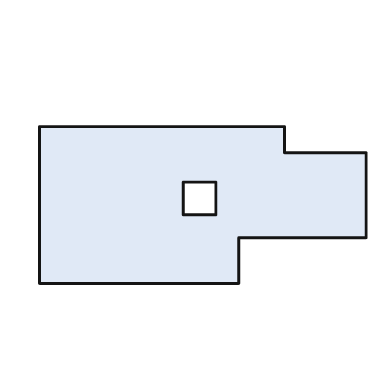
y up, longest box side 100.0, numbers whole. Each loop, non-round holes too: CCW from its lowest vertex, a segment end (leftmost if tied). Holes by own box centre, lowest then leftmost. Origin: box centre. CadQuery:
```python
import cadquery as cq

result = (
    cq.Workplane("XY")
    .moveTo(-50.0, -24.0)
    .lineTo(11.0, -24.0)
    .lineTo(11.0, -10.0)
    .lineTo(50.0, -10.0)
    .lineTo(50.0, 16.0)
    .lineTo(25.0, 16.0)
    .lineTo(25.0, 24.0)
    .lineTo(-50.0, 24.0)
    .close()
    .moveTo(-6.0, -3.0)
    .lineTo(4.0, -3.0)
    .lineTo(4.0, 7.0)
    .lineTo(-6.0, 7.0)
    .close()
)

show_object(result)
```